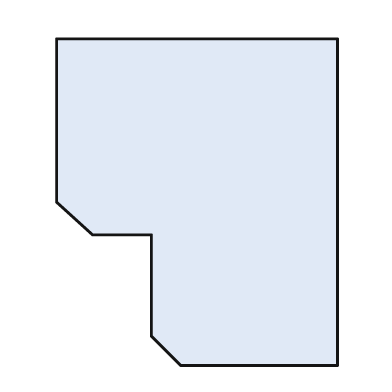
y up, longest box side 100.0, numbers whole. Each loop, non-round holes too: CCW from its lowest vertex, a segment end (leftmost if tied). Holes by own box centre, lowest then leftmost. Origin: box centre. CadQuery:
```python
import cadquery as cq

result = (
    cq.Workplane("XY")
    .moveTo(-5.0, -50.0)
    .lineTo(43.0, -50.0)
    .lineTo(43.0, 50.0)
    .lineTo(-43.0, 50.0)
    .lineTo(-43.0, 0.0)
    .lineTo(-32.0, -10.0)
    .lineTo(-14.0, -10.0)
    .lineTo(-14.0, -41.0)
    .close()
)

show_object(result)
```